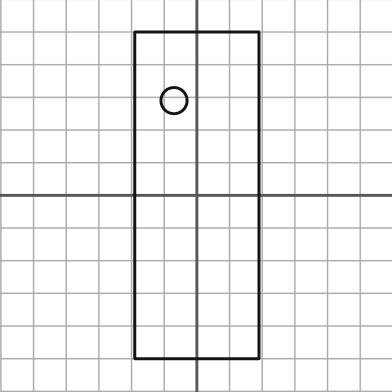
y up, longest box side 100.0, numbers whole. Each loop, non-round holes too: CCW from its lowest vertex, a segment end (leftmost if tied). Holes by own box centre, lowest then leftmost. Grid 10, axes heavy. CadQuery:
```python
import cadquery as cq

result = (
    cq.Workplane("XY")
    .moveTo(-19.0, -50.0)
    .lineTo(19.0, -50.0)
    .lineTo(19.0, 50.0)
    .lineTo(-19.0, 50.0)
    .close()
    .moveTo(-7.0, 29.0)
    .circle(4.0)
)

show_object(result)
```